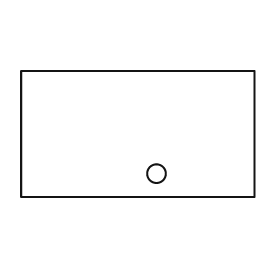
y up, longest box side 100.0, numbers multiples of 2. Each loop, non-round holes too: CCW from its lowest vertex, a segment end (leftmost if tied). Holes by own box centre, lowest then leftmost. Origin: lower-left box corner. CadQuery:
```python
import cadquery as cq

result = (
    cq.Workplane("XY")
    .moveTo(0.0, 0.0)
    .lineTo(100.0, 0.0)
    .lineTo(100.0, 54.0)
    .lineTo(0.0, 54.0)
    .close()
    .moveTo(58.0, 10.0)
    .circle(4.0)
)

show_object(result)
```